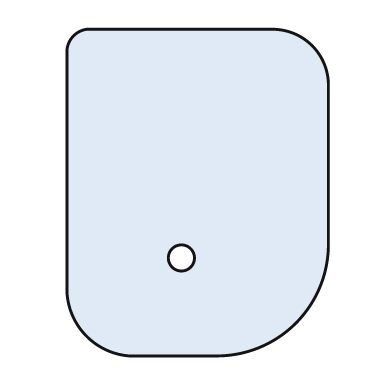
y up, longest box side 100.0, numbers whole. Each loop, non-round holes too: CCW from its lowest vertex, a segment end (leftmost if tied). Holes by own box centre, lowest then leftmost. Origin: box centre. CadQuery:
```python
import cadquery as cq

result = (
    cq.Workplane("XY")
    .moveTo(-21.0, -50.0)
    .lineTo(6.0, -50.0)
    .threePointArc((30.0, -40.0), (40.0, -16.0))
    .lineTo(40.0, 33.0)
    .threePointArc((35.0, 45.0), (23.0, 50.0))
    .lineTo(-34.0, 50.0)
    .threePointArc((-38.0, 48.0), (-40.0, 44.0))
    .lineTo(-40.0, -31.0)
    .threePointArc((-34.0, -44.0), (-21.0, -50.0))
    .close()
    .moveTo(-5.0, -20.0)
    .circle(4.0)
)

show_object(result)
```